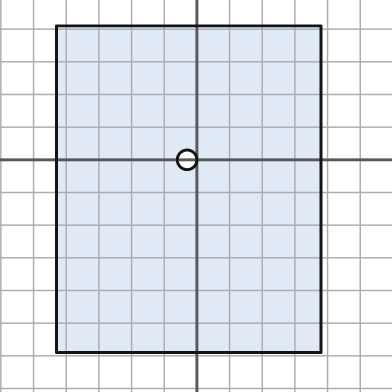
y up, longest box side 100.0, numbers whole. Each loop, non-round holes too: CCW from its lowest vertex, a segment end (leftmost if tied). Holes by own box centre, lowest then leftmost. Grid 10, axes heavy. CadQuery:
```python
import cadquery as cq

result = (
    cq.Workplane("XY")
    .moveTo(-43.0, -59.0)
    .lineTo(38.0, -59.0)
    .lineTo(38.0, 41.0)
    .lineTo(-43.0, 41.0)
    .close()
    .moveTo(-3.0, 0.0)
    .circle(3.0)
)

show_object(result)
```